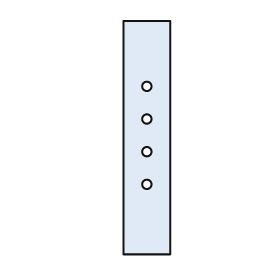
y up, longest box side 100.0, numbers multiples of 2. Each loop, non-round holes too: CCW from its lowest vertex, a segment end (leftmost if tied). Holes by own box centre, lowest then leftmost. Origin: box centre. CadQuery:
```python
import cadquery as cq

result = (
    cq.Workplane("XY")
    .moveTo(-10.0, -50.0)
    .lineTo(10.0, -50.0)
    .lineTo(10.0, 50.0)
    .lineTo(-10.0, 50.0)
    .close()
    .moveTo(0.0, -20.0)
    .circle(2.0)
    .moveTo(0.0, -6.0)
    .circle(2.0)
    .moveTo(0.0, 8.0)
    .circle(2.0)
    .moveTo(0.0, 22.0)
    .circle(2.0)
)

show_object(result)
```